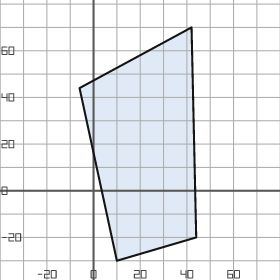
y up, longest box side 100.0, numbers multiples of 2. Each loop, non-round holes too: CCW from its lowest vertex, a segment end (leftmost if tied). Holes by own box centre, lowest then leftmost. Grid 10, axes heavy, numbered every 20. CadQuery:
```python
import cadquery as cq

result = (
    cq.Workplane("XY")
    .moveTo(10.0, -30.0)
    .lineTo(44.0, -20.0)
    .lineTo(42.0, 70.0)
    .lineTo(-6.0, 44.0)
    .close()
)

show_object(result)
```